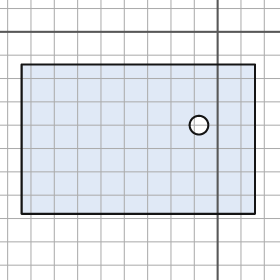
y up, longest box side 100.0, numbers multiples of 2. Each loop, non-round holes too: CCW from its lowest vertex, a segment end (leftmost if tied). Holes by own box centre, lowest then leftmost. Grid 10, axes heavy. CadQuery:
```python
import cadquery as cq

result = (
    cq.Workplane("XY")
    .moveTo(-84.0, -78.0)
    .lineTo(16.0, -78.0)
    .lineTo(16.0, -14.0)
    .lineTo(-84.0, -14.0)
    .close()
    .moveTo(-8.0, -40.0)
    .circle(4.0)
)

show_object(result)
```